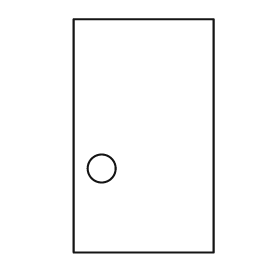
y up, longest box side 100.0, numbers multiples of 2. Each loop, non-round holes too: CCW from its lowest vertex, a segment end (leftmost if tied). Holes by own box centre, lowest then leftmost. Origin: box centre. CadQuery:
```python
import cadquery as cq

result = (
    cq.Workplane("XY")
    .moveTo(-30.0, -50.0)
    .lineTo(30.0, -50.0)
    .lineTo(30.0, 50.0)
    .lineTo(-30.0, 50.0)
    .close()
    .moveTo(-18.0, -14.0)
    .circle(6.0)
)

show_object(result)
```